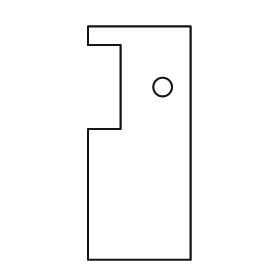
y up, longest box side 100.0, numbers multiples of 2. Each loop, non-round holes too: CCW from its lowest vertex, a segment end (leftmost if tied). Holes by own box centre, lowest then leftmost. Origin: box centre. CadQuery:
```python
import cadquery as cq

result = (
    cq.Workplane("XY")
    .moveTo(-22.0, -50.0)
    .lineTo(22.0, -50.0)
    .lineTo(22.0, 50.0)
    .lineTo(-22.0, 50.0)
    .lineTo(-22.0, 42.0)
    .lineTo(-8.0, 42.0)
    .lineTo(-8.0, 6.0)
    .lineTo(-22.0, 6.0)
    .close()
    .moveTo(10.0, 24.0)
    .circle(4.0)
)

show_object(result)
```